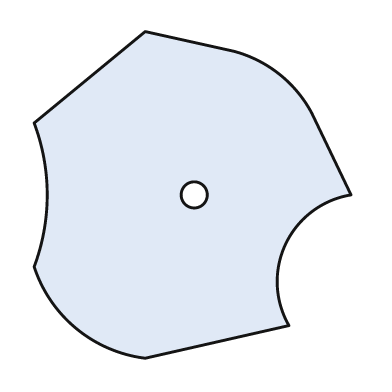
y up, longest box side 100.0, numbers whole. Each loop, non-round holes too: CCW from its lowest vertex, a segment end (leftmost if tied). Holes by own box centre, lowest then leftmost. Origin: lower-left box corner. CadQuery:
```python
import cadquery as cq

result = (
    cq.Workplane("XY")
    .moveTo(34.0, 0.0)
    .lineTo(78.0, 10.0)
    .threePointArc((77.0, 35.0), (97.0, 50.0))
    .lineTo(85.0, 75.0)
    .threePointArc((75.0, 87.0), (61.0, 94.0))
    .lineTo(34.0, 100.0)
    .lineTo(0.0, 72.0)
    .threePointArc((4.0, 50.0), (0.0, 28.0))
    .threePointArc((13.0, 9.0), (34.0, 0.0))
    .close()
    .moveTo(49.0, 50.0)
    .circle(4.0)
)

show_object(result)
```